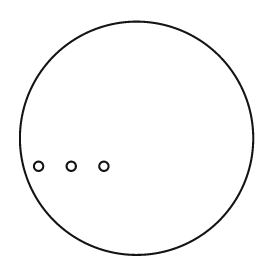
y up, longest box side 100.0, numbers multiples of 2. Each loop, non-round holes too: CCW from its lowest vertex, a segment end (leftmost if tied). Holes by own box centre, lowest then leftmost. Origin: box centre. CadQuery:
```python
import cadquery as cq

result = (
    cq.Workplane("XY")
    .moveTo(0.0, 0.0)
    .circle(50.0)
    .moveTo(-42.0, -12.0)
    .circle(2.0)
    .moveTo(-28.0, -12.0)
    .circle(2.0)
    .moveTo(-14.0, -12.0)
    .circle(2.0)
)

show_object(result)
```